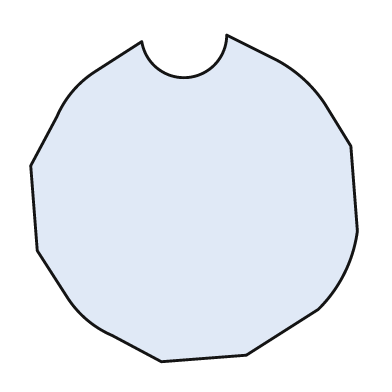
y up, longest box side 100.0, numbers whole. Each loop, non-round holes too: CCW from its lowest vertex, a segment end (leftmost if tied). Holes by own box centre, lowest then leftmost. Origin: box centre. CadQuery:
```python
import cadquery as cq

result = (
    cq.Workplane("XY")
    .moveTo(-10.0, -50.0)
    .lineTo(16.0, -48.0)
    .lineTo(38.0, -34.0)
    .threePointArc((46.0, -23.0), (50.0, -10.0))
    .lineTo(48.0, 16.0)
    .lineTo(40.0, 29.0)
    .threePointArc((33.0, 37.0), (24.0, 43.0))
    .lineTo(10.0, 50.0)
    .threePointArc((-2.0, 37.0), (-16.0, 48.0))
    .lineTo(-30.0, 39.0)
    .threePointArc((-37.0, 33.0), (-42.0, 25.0))
    .lineTo(-50.0, 10.0)
    .lineTo(-48.0, -16.0)
    .lineTo(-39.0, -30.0)
    .threePointArc((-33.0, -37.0), (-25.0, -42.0))
    .close()
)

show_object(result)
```